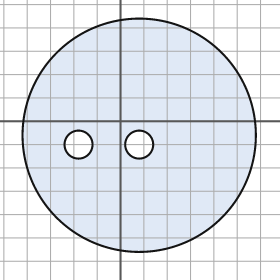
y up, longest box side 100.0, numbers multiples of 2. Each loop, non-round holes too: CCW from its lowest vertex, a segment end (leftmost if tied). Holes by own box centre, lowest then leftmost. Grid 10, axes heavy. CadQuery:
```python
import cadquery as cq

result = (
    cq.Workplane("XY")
    .moveTo(8.0, -6.0)
    .circle(50.0)
    .moveTo(-18.0, -10.0)
    .circle(6.0)
    .moveTo(8.0, -10.0)
    .circle(6.0)
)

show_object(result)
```